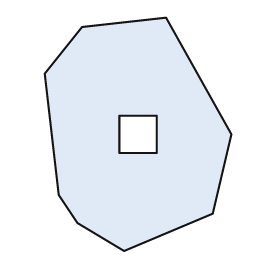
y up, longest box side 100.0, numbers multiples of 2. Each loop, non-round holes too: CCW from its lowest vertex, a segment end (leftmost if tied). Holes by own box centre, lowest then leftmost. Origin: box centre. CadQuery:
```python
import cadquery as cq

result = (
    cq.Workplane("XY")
    .moveTo(-6.0, -50.0)
    .lineTo(32.0, -34.0)
    .lineTo(40.0, 0.0)
    .lineTo(12.0, 50.0)
    .lineTo(-24.0, 46.0)
    .lineTo(-40.0, 26.0)
    .lineTo(-34.0, -26.0)
    .lineTo(-26.0, -38.0)
    .close()
    .moveTo(-8.0, -8.0)
    .lineTo(8.0, -8.0)
    .lineTo(8.0, 8.0)
    .lineTo(-8.0, 8.0)
    .close()
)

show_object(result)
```